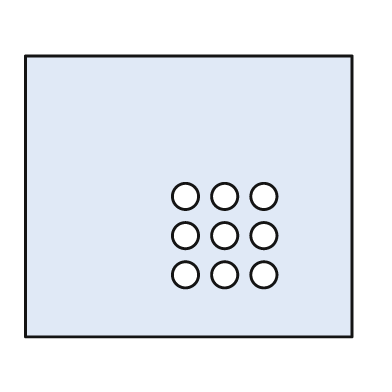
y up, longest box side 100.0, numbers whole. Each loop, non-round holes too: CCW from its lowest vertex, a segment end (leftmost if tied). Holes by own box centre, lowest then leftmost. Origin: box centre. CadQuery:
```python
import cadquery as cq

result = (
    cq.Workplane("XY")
    .moveTo(-50.0, -43.0)
    .lineTo(50.0, -43.0)
    .lineTo(50.0, 43.0)
    .lineTo(-50.0, 43.0)
    .close()
    .moveTo(-1.0, -24.0)
    .circle(4.0)
    .moveTo(11.0, -24.0)
    .circle(4.0)
    .moveTo(23.0, -24.0)
    .circle(4.0)
    .moveTo(-1.0, -12.0)
    .circle(4.0)
    .moveTo(11.0, -12.0)
    .circle(4.0)
    .moveTo(23.0, -12.0)
    .circle(4.0)
    .moveTo(-1.0, 0.0)
    .circle(4.0)
    .moveTo(11.0, 0.0)
    .circle(4.0)
    .moveTo(23.0, 0.0)
    .circle(4.0)
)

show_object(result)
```